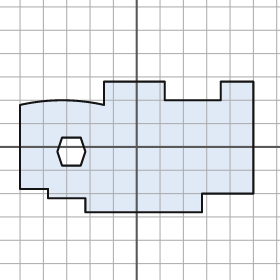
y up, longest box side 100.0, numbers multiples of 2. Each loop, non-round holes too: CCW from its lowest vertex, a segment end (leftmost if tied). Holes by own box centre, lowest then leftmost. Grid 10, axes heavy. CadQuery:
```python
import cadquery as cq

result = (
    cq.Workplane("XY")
    .moveTo(-22.0, -28.0)
    .lineTo(28.0, -28.0)
    .lineTo(28.0, -20.0)
    .lineTo(50.0, -20.0)
    .lineTo(50.0, 28.0)
    .lineTo(36.0, 28.0)
    .lineTo(36.0, 20.0)
    .lineTo(12.0, 20.0)
    .lineTo(12.0, 28.0)
    .lineTo(-14.0, 28.0)
    .lineTo(-14.0, 18.0)
    .threePointArc((-32.0, 20.0), (-50.0, 18.0))
    .lineTo(-50.0, -18.0)
    .lineTo(-38.0, -18.0)
    .lineTo(-38.0, -22.0)
    .lineTo(-22.0, -22.0)
    .close()
    .moveTo(-32.0, -8.0)
    .lineTo(-24.0, -8.0)
    .lineTo(-22.0, -2.0)
    .lineTo(-24.0, 4.0)
    .lineTo(-32.0, 4.0)
    .lineTo(-34.0, -2.0)
    .close()
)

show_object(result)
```